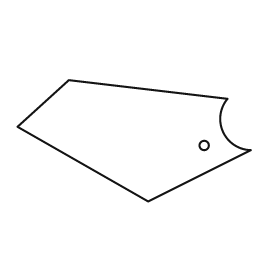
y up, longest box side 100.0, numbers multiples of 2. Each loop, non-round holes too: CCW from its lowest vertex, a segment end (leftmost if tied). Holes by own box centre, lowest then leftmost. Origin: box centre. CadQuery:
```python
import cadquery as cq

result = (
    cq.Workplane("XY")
    .moveTo(6.0, -26.0)
    .lineTo(50.0, -4.0)
    .threePointArc((38.0, 4.0), (40.0, 18.0))
    .lineTo(-28.0, 26.0)
    .lineTo(-50.0, 6.0)
    .close()
    .moveTo(30.0, -2.0)
    .circle(2.0)
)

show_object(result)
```